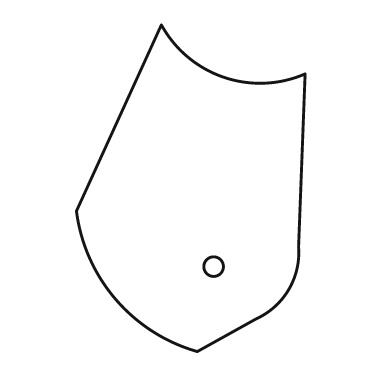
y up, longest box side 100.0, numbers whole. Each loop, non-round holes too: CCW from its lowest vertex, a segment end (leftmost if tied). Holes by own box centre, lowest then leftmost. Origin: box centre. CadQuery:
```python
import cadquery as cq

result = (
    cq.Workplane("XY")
    .moveTo(2.0, -50.0)
    .lineTo(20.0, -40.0)
    .threePointArc((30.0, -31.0), (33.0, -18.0))
    .lineTo(35.0, 35.0)
    .threePointArc((10.0, 34.0), (-9.0, 50.0))
    .lineTo(-35.0, -7.0)
    .threePointArc((-23.0, -34.0), (2.0, -50.0))
    .close()
    .moveTo(7.0, -24.0)
    .circle(3.0)
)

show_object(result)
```